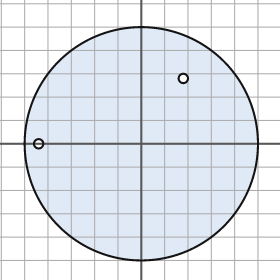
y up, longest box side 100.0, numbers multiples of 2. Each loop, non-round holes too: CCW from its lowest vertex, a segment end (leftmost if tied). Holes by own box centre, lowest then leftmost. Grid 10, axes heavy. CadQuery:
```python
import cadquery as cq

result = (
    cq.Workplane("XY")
    .moveTo(0.0, 0.0)
    .circle(50.0)
    .moveTo(-44.0, 0.0)
    .circle(2.0)
    .moveTo(18.0, 28.0)
    .circle(2.0)
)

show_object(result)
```